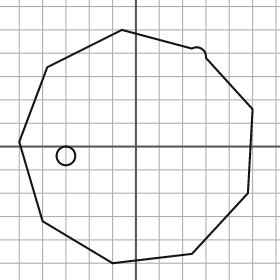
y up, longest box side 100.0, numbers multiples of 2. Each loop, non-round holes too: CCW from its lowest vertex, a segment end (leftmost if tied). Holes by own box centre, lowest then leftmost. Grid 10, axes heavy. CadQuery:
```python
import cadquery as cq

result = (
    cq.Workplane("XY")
    .moveTo(-10.0, -50.0)
    .lineTo(24.0, -46.0)
    .lineTo(48.0, -20.0)
    .lineTo(50.0, 16.0)
    .lineTo(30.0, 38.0)
    .threePointArc((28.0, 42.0), (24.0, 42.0))
    .lineTo(-6.0, 50.0)
    .lineTo(-38.0, 34.0)
    .lineTo(-50.0, 2.0)
    .lineTo(-40.0, -32.0)
    .close()
    .moveTo(-30.0, -4.0)
    .circle(4.0)
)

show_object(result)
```